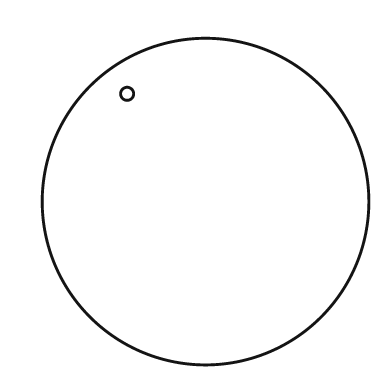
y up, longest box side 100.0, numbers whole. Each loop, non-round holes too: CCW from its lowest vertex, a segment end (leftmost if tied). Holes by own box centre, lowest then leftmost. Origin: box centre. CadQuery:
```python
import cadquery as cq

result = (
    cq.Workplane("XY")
    .moveTo(0.0, 0.0)
    .circle(50.0)
    .moveTo(-24.0, 33.0)
    .circle(2.0)
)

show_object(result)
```